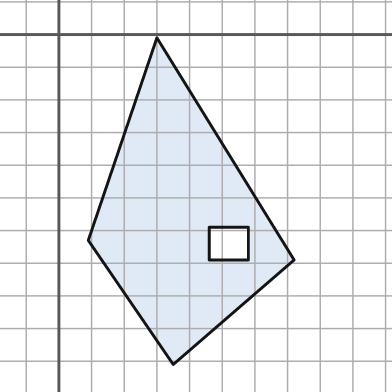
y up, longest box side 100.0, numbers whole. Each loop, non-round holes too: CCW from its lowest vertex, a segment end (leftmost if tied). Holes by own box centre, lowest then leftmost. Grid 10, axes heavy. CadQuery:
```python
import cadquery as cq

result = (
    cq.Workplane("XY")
    .moveTo(35.0, -101.0)
    .lineTo(72.0, -69.0)
    .lineTo(30.0, -1.0)
    .lineTo(9.0, -63.0)
    .close()
    .moveTo(46.0, -69.0)
    .lineTo(58.0, -69.0)
    .lineTo(58.0, -59.0)
    .lineTo(46.0, -59.0)
    .close()
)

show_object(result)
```